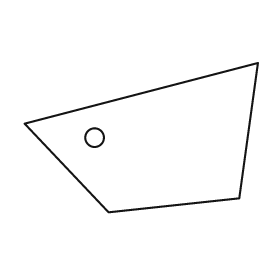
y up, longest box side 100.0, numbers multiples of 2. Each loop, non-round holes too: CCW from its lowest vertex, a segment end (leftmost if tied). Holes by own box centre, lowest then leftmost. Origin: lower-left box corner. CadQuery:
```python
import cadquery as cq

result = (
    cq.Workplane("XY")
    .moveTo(36.0, 0.0)
    .lineTo(92.0, 6.0)
    .lineTo(100.0, 64.0)
    .lineTo(0.0, 38.0)
    .close()
    .moveTo(30.0, 32.0)
    .circle(4.0)
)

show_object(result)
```